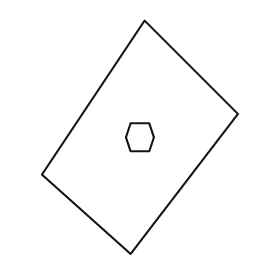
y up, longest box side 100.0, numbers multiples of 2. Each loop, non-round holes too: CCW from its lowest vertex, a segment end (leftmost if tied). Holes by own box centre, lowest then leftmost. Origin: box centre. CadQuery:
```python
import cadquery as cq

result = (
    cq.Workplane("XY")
    .moveTo(-4.0, -50.0)
    .lineTo(42.0, 10.0)
    .lineTo(2.0, 50.0)
    .lineTo(-42.0, -16.0)
    .close()
    .moveTo(-4.0, -6.0)
    .lineTo(4.0, -6.0)
    .lineTo(6.0, 0.0)
    .lineTo(4.0, 6.0)
    .lineTo(-4.0, 6.0)
    .lineTo(-6.0, 0.0)
    .close()
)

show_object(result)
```